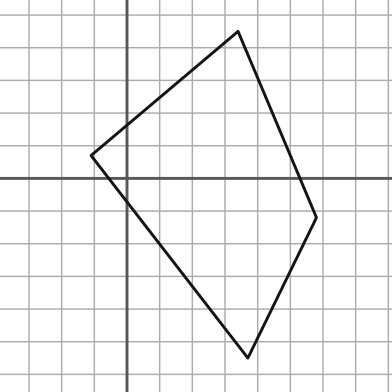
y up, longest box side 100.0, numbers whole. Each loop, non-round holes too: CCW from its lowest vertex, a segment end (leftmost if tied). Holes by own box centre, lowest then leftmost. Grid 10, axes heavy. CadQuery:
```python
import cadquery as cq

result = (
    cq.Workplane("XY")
    .moveTo(37.0, -55.0)
    .lineTo(58.0, -12.0)
    .lineTo(34.0, 45.0)
    .lineTo(-11.0, 7.0)
    .close()
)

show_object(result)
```